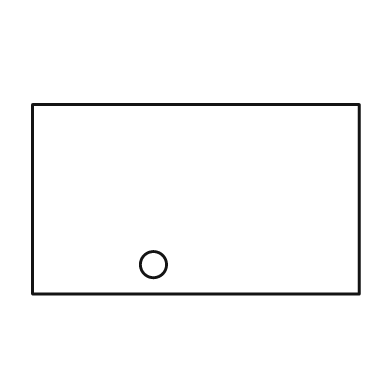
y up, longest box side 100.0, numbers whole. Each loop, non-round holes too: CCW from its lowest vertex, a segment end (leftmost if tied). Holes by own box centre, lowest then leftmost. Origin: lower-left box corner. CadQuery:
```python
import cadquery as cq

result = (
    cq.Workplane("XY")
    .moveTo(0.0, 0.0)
    .lineTo(100.0, 0.0)
    .lineTo(100.0, 58.0)
    .lineTo(0.0, 58.0)
    .close()
    .moveTo(37.0, 9.0)
    .circle(4.0)
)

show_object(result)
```